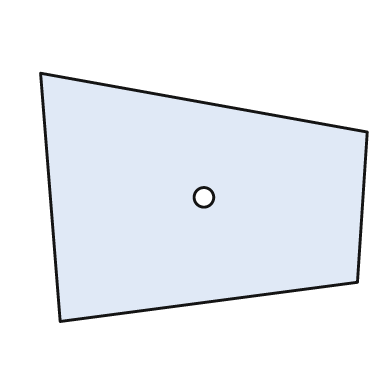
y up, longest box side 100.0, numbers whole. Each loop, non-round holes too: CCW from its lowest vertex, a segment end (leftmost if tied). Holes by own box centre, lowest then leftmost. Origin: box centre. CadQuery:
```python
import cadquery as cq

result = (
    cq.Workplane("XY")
    .moveTo(-44.0, -38.0)
    .lineTo(47.0, -26.0)
    .lineTo(50.0, 20.0)
    .lineTo(-50.0, 38.0)
    .close()
    .moveTo(0.0, 0.0)
    .circle(3.0)
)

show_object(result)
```